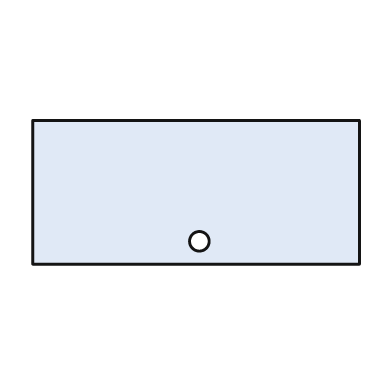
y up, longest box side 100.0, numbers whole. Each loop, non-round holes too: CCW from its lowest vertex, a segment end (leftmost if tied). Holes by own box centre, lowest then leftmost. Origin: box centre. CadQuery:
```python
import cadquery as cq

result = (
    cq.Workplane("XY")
    .moveTo(-50.0, -22.0)
    .lineTo(50.0, -22.0)
    .lineTo(50.0, 22.0)
    .lineTo(-50.0, 22.0)
    .close()
    .moveTo(1.0, -15.0)
    .circle(3.0)
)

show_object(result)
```